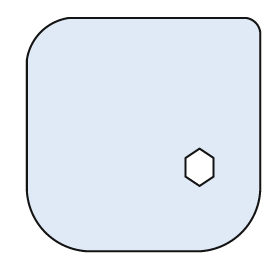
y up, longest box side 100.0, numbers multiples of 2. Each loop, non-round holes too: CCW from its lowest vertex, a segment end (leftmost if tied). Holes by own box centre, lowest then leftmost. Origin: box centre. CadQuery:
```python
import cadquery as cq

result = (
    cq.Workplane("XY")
    .moveTo(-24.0, -50.0)
    .lineTo(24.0, -50.0)
    .threePointArc((42.0, -42.0), (50.0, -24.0))
    .lineTo(50.0, 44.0)
    .threePointArc((48.0, 48.0), (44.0, 50.0))
    .lineTo(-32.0, 50.0)
    .threePointArc((-44.0, 44.0), (-50.0, 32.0))
    .lineTo(-50.0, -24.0)
    .threePointArc((-42.0, -42.0), (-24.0, -50.0))
    .close()
    .moveTo(24.0, -22.0)
    .lineTo(30.0, -18.0)
    .lineTo(30.0, -10.0)
    .lineTo(24.0, -6.0)
    .lineTo(18.0, -10.0)
    .lineTo(18.0, -18.0)
    .close()
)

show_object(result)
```